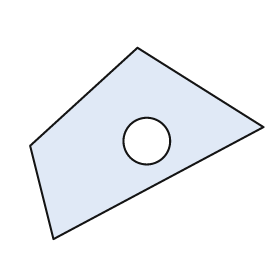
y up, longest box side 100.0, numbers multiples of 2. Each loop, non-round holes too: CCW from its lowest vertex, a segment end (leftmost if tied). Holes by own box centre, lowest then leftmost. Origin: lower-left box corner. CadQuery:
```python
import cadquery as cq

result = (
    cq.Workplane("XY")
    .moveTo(10.0, 0.0)
    .lineTo(100.0, 48.0)
    .lineTo(46.0, 82.0)
    .lineTo(0.0, 40.0)
    .close()
    .moveTo(50.0, 42.0)
    .circle(10.0)
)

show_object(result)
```